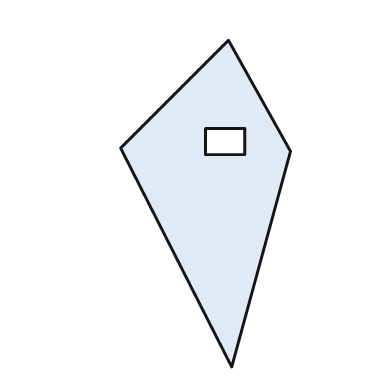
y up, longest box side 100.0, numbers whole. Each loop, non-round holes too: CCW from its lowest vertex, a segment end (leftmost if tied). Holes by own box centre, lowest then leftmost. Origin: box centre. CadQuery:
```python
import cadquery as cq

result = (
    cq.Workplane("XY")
    .moveTo(8.0, -50.0)
    .lineTo(26.0, 16.0)
    .lineTo(7.0, 50.0)
    .lineTo(-26.0, 17.0)
    .close()
    .moveTo(0.0, 15.0)
    .lineTo(12.0, 15.0)
    .lineTo(12.0, 23.0)
    .lineTo(0.0, 23.0)
    .close()
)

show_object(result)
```